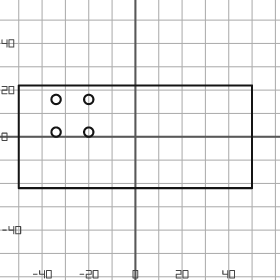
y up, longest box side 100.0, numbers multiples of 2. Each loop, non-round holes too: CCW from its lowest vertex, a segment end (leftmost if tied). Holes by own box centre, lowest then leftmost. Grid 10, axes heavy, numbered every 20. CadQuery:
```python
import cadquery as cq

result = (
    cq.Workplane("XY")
    .moveTo(-50.0, -22.0)
    .lineTo(50.0, -22.0)
    .lineTo(50.0, 22.0)
    .lineTo(-50.0, 22.0)
    .close()
    .moveTo(-34.0, 2.0)
    .circle(2.0)
    .moveTo(-20.0, 2.0)
    .circle(2.0)
    .moveTo(-34.0, 16.0)
    .circle(2.0)
    .moveTo(-20.0, 16.0)
    .circle(2.0)
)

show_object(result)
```